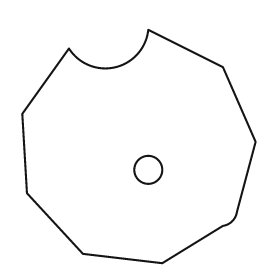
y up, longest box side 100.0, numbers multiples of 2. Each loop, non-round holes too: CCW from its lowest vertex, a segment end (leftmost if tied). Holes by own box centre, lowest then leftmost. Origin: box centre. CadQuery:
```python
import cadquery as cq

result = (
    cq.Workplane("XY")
    .moveTo(10.0, -50.0)
    .lineTo(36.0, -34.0)
    .threePointArc((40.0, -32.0), (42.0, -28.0))
    .lineTo(50.0, 2.0)
    .lineTo(36.0, 34.0)
    .lineTo(4.0, 50.0)
    .threePointArc((-10.0, 34.0), (-30.0, 42.0))
    .lineTo(-50.0, 14.0)
    .lineTo(-48.0, -20.0)
    .lineTo(-24.0, -46.0)
    .close()
    .moveTo(4.0, -10.0)
    .circle(6.0)
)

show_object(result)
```